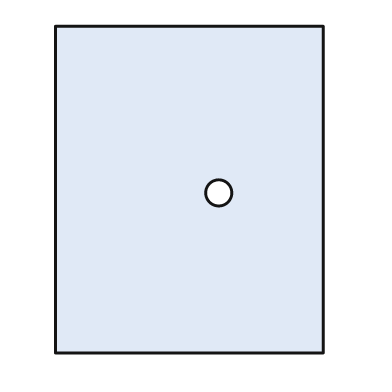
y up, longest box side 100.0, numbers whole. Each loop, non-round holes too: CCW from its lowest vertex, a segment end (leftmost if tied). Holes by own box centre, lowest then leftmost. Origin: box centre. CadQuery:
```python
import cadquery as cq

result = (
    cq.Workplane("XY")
    .moveTo(-41.0, -50.0)
    .lineTo(41.0, -50.0)
    .lineTo(41.0, 50.0)
    .lineTo(-41.0, 50.0)
    .close()
    .moveTo(9.0, -1.0)
    .circle(4.0)
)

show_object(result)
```